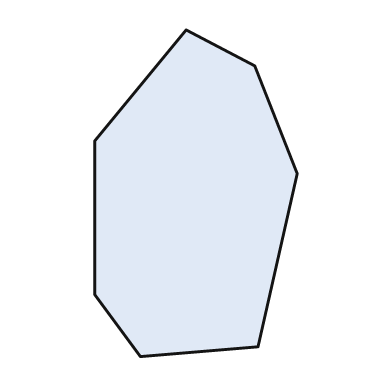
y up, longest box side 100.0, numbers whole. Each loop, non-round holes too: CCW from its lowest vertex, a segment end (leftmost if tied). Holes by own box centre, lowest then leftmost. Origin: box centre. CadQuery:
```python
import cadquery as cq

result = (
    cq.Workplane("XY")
    .moveTo(-17.0, -50.0)
    .lineTo(19.0, -47.0)
    .lineTo(31.0, 6.0)
    .lineTo(18.0, 39.0)
    .lineTo(-3.0, 50.0)
    .lineTo(-31.0, 16.0)
    .lineTo(-31.0, -31.0)
    .close()
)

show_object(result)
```